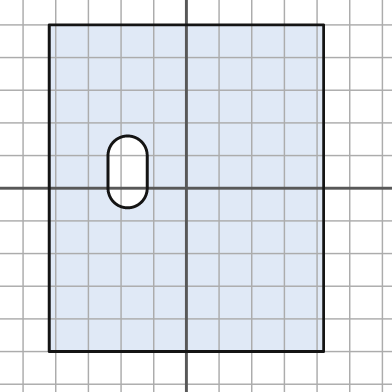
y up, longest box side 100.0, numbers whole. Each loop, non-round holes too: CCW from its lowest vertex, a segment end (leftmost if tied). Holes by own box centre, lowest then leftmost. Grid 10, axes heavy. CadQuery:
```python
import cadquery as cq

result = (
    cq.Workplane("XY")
    .moveTo(-42.0, -50.0)
    .lineTo(42.0, -50.0)
    .lineTo(42.0, 50.0)
    .lineTo(-42.0, 50.0)
    .close()
    .moveTo(-24.0, 0.0)
    .threePointArc((-18.0, -6.0), (-12.0, 0.0))
    .lineTo(-12.0, 10.0)
    .threePointArc((-18.0, 16.0), (-24.0, 10.0))
    .close()
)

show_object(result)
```